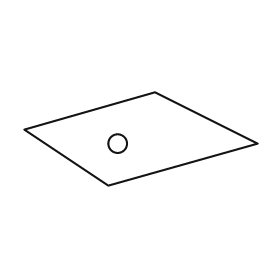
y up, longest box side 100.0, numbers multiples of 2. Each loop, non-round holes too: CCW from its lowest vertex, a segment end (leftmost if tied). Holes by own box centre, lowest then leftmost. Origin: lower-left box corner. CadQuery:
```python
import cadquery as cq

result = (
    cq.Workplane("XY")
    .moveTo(36.0, 0.0)
    .lineTo(100.0, 18.0)
    .lineTo(56.0, 40.0)
    .lineTo(0.0, 24.0)
    .close()
    .moveTo(40.0, 18.0)
    .circle(4.0)
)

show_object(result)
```